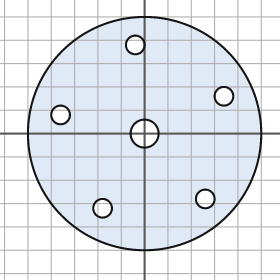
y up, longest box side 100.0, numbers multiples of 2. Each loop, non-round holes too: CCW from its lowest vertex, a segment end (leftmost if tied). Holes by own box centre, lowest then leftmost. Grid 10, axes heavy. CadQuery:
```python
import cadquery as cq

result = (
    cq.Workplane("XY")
    .moveTo(0.0, 0.0)
    .circle(50.0)
    .moveTo(-18.0, -32.0)
    .circle(4.0)
    .moveTo(26.0, -28.0)
    .circle(4.0)
    .moveTo(0.0, 0.0)
    .circle(6.0)
    .moveTo(-36.0, 8.0)
    .circle(4.0)
    .moveTo(34.0, 16.0)
    .circle(4.0)
    .moveTo(-4.0, 38.0)
    .circle(4.0)
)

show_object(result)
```